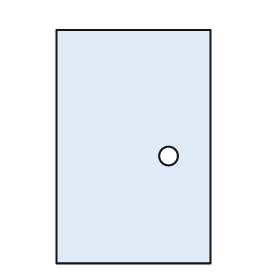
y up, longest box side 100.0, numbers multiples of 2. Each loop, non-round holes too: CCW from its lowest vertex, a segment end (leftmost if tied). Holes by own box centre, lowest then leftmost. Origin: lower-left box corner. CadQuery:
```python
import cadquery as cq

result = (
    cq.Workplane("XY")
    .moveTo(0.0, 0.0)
    .lineTo(66.0, 0.0)
    .lineTo(66.0, 100.0)
    .lineTo(0.0, 100.0)
    .close()
    .moveTo(48.0, 46.0)
    .circle(4.0)
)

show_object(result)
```